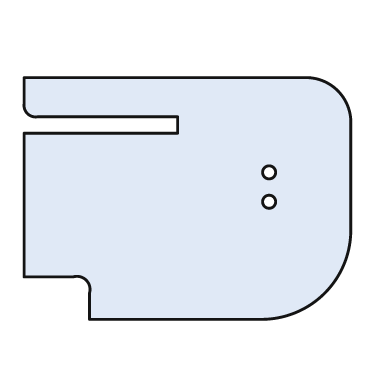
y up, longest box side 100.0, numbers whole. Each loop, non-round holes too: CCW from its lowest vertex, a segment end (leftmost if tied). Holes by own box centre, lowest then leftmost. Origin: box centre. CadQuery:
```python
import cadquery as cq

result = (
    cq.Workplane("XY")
    .moveTo(-30.0, -37.0)
    .lineTo(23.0, -37.0)
    .threePointArc((42.0, -29.0), (50.0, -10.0))
    .lineTo(50.0, 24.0)
    .threePointArc((46.0, 33.0), (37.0, 37.0))
    .lineTo(-50.0, 37.0)
    .lineTo(-50.0, 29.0)
    .threePointArc((-49.0, 26.0), (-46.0, 25.0))
    .lineTo(-3.0, 25.0)
    .lineTo(-3.0, 20.0)
    .lineTo(-50.0, 20.0)
    .lineTo(-50.0, -24.0)
    .lineTo(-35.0, -24.0)
    .threePointArc((-31.0, -25.0), (-30.0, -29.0))
    .close()
    .moveTo(25.0, -1.0)
    .circle(2.0)
    .moveTo(25.0, 8.0)
    .circle(2.0)
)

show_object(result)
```